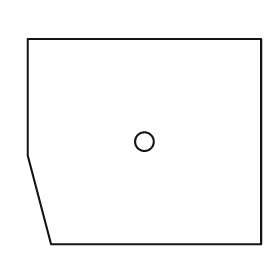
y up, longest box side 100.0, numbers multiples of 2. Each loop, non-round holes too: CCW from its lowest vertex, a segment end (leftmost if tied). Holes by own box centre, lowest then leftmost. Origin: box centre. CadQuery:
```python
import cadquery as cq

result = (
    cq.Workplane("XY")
    .moveTo(-40.0, -44.0)
    .lineTo(50.0, -44.0)
    .lineTo(50.0, 44.0)
    .lineTo(-50.0, 44.0)
    .lineTo(-50.0, -6.0)
    .close()
    .moveTo(0.0, 0.0)
    .circle(4.0)
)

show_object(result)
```